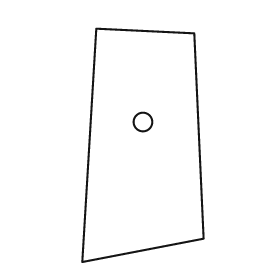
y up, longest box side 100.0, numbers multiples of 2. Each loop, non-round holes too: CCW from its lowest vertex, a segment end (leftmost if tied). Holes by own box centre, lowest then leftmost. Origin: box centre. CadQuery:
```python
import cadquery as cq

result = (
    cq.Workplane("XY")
    .moveTo(-26.0, -50.0)
    .lineTo(26.0, -40.0)
    .lineTo(22.0, 48.0)
    .lineTo(-20.0, 50.0)
    .close()
    .moveTo(0.0, 10.0)
    .circle(4.0)
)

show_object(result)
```